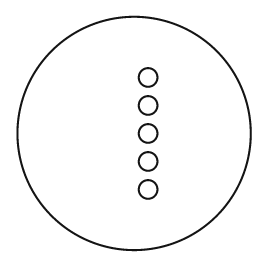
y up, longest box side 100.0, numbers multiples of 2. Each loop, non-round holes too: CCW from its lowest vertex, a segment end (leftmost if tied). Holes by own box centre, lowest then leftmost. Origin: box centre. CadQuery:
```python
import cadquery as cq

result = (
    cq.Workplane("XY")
    .moveTo(0.0, 0.0)
    .circle(50.0)
    .moveTo(6.0, -24.0)
    .circle(4.0)
    .moveTo(6.0, -12.0)
    .circle(4.0)
    .moveTo(6.0, 0.0)
    .circle(4.0)
    .moveTo(6.0, 12.0)
    .circle(4.0)
    .moveTo(6.0, 24.0)
    .circle(4.0)
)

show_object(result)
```